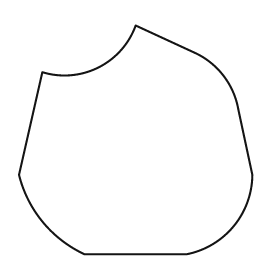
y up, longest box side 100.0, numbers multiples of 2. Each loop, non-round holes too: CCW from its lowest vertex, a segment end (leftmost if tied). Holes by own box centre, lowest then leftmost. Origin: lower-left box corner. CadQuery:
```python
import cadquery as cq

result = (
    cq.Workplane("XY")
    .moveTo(28.0, 0.0)
    .lineTo(72.0, 0.0)
    .threePointArc((92.0, 12.0), (100.0, 34.0))
    .lineTo(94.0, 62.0)
    .threePointArc((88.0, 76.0), (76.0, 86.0))
    .lineTo(50.0, 98.0)
    .threePointArc((34.0, 80.0), (10.0, 78.0))
    .lineTo(0.0, 34.0)
    .threePointArc((10.0, 14.0), (28.0, 0.0))
    .close()
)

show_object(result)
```